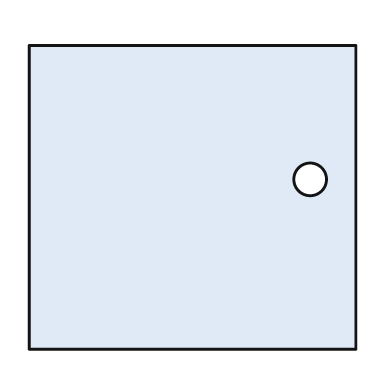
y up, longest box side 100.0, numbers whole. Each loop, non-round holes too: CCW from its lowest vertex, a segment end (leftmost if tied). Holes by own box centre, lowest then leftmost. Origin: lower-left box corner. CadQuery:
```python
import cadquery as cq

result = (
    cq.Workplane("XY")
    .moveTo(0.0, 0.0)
    .lineTo(100.0, 0.0)
    .lineTo(100.0, 93.0)
    .lineTo(0.0, 93.0)
    .close()
    .moveTo(86.0, 52.0)
    .circle(5.0)
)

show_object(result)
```